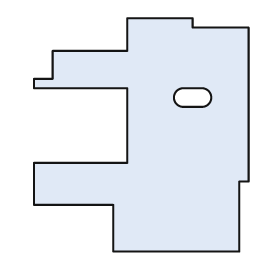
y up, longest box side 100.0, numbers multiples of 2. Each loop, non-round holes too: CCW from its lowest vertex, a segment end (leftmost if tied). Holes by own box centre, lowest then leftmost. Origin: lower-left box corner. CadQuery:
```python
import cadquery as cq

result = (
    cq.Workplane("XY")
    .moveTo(34.0, 0.0)
    .lineTo(88.0, 0.0)
    .lineTo(88.0, 30.0)
    .lineTo(92.0, 30.0)
    .lineTo(92.0, 96.0)
    .lineTo(68.0, 96.0)
    .lineTo(68.0, 100.0)
    .lineTo(40.0, 100.0)
    .lineTo(40.0, 86.0)
    .lineTo(8.0, 86.0)
    .lineTo(8.0, 74.0)
    .lineTo(0.0, 74.0)
    .lineTo(0.0, 70.0)
    .lineTo(40.0, 70.0)
    .lineTo(40.0, 38.0)
    .lineTo(0.0, 38.0)
    .lineTo(0.0, 20.0)
    .lineTo(34.0, 20.0)
    .close()
    .moveTo(64.0, 62.0)
    .lineTo(72.0, 62.0)
    .threePointArc((76.0, 66.0), (72.0, 70.0))
    .lineTo(64.0, 70.0)
    .threePointArc((60.0, 66.0), (64.0, 62.0))
    .close()
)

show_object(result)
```